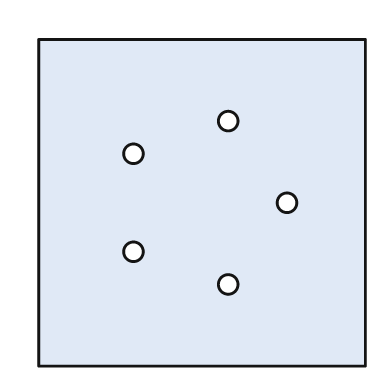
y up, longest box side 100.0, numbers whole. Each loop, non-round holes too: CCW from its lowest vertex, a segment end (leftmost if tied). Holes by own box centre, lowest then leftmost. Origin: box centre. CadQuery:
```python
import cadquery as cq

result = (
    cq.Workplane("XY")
    .moveTo(-50.0, -50.0)
    .lineTo(50.0, -50.0)
    .lineTo(50.0, 50.0)
    .lineTo(-50.0, 50.0)
    .close()
    .moveTo(8.0, -25.0)
    .circle(3.0)
    .moveTo(-21.0, -15.0)
    .circle(3.0)
    .moveTo(26.0, 0.0)
    .circle(3.0)
    .moveTo(-21.0, 15.0)
    .circle(3.0)
    .moveTo(8.0, 25.0)
    .circle(3.0)
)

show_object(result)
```